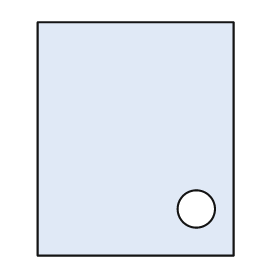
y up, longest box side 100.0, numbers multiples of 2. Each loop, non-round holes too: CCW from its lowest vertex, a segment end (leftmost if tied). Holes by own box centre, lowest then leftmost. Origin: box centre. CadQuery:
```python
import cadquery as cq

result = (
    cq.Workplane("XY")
    .moveTo(-42.0, -50.0)
    .lineTo(42.0, -50.0)
    .lineTo(42.0, 50.0)
    .lineTo(-42.0, 50.0)
    .close()
    .moveTo(26.0, -30.0)
    .circle(8.0)
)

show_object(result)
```